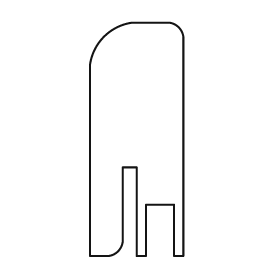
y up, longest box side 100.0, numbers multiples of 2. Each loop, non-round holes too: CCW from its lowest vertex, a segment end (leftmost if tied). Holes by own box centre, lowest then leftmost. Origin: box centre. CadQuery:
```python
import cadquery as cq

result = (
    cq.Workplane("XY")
    .moveTo(-20.0, -50.0)
    .lineTo(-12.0, -50.0)
    .threePointArc((-8.0, -48.0), (-6.0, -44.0))
    .lineTo(-6.0, -12.0)
    .lineTo(0.0, -12.0)
    .lineTo(0.0, -50.0)
    .lineTo(4.0, -50.0)
    .lineTo(4.0, -28.0)
    .lineTo(16.0, -28.0)
    .lineTo(16.0, -50.0)
    .lineTo(20.0, -50.0)
    .lineTo(20.0, 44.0)
    .threePointArc((18.0, 48.0), (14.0, 50.0))
    .lineTo(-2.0, 50.0)
    .threePointArc((-14.0, 44.0), (-20.0, 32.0))
    .close()
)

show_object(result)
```